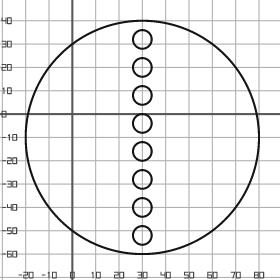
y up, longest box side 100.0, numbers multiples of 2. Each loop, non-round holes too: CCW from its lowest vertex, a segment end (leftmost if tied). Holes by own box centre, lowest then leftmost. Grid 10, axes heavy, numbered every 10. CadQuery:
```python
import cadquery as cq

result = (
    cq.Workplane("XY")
    .moveTo(30.0, -10.0)
    .circle(50.0)
    .moveTo(30.0, -52.0)
    .circle(4.0)
    .moveTo(30.0, -40.0)
    .circle(4.0)
    .moveTo(30.0, -28.0)
    .circle(4.0)
    .moveTo(30.0, -16.0)
    .circle(4.0)
    .moveTo(30.0, -4.0)
    .circle(4.0)
    .moveTo(30.0, 8.0)
    .circle(4.0)
    .moveTo(30.0, 20.0)
    .circle(4.0)
    .moveTo(30.0, 32.0)
    .circle(4.0)
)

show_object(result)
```